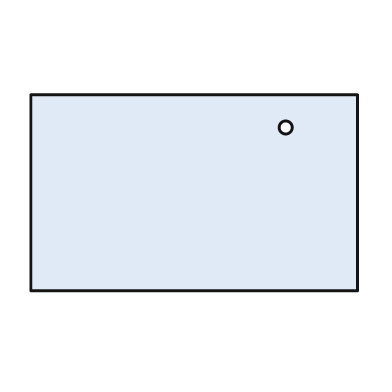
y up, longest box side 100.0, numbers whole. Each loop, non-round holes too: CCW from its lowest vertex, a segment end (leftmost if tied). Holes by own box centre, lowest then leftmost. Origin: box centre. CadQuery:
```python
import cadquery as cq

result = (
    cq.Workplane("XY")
    .moveTo(-50.0, -30.0)
    .lineTo(50.0, -30.0)
    .lineTo(50.0, 30.0)
    .lineTo(-50.0, 30.0)
    .close()
    .moveTo(28.0, 20.0)
    .circle(2.0)
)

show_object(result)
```